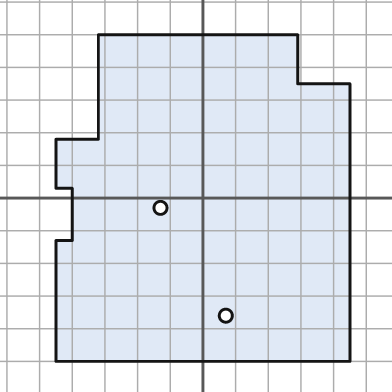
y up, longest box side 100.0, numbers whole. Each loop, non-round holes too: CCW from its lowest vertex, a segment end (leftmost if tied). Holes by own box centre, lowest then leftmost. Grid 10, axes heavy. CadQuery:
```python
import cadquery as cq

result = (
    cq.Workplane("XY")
    .moveTo(-45.0, -50.0)
    .lineTo(45.0, -50.0)
    .lineTo(45.0, 35.0)
    .lineTo(29.0, 35.0)
    .lineTo(29.0, 50.0)
    .lineTo(-32.0, 50.0)
    .lineTo(-32.0, 18.0)
    .lineTo(-45.0, 18.0)
    .lineTo(-45.0, 3.0)
    .lineTo(-40.0, 3.0)
    .lineTo(-40.0, -13.0)
    .lineTo(-45.0, -13.0)
    .close()
    .moveTo(7.0, -36.0)
    .circle(2.0)
    .moveTo(-13.0, -3.0)
    .circle(2.0)
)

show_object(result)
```